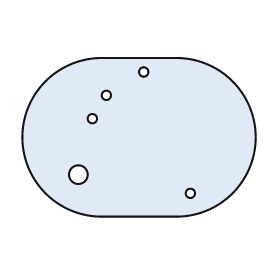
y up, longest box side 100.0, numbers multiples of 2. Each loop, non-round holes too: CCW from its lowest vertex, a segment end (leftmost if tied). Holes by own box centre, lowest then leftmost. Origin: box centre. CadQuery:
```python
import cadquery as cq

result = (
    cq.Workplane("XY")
    .moveTo(-16.0, -34.0)
    .lineTo(16.0, -34.0)
    .threePointArc((50.0, 0.0), (16.0, 34.0))
    .lineTo(-16.0, 34.0)
    .threePointArc((-50.0, 0.0), (-16.0, -34.0))
    .close()
    .moveTo(22.0, -24.0)
    .circle(2.0)
    .moveTo(-26.0, -16.0)
    .circle(4.0)
    .moveTo(-20.0, 8.0)
    .circle(2.0)
    .moveTo(-14.0, 18.0)
    .circle(2.0)
    .moveTo(2.0, 28.0)
    .circle(2.0)
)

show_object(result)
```